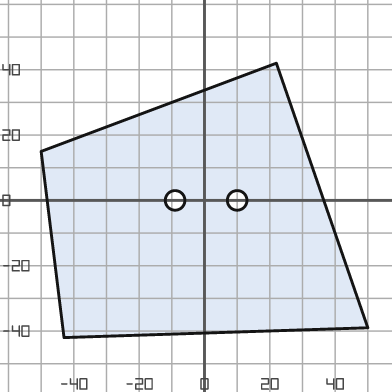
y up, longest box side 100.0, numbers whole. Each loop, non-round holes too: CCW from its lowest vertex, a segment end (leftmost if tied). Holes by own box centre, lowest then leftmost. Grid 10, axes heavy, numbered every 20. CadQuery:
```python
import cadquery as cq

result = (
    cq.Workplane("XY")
    .moveTo(-43.0, -42.0)
    .lineTo(50.0, -39.0)
    .lineTo(22.0, 42.0)
    .lineTo(-50.0, 15.0)
    .close()
    .moveTo(-9.0, 0.0)
    .circle(3.0)
    .moveTo(10.0, 0.0)
    .circle(3.0)
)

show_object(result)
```